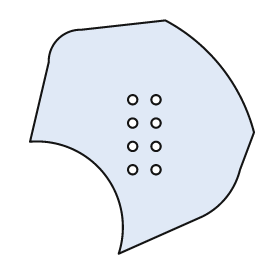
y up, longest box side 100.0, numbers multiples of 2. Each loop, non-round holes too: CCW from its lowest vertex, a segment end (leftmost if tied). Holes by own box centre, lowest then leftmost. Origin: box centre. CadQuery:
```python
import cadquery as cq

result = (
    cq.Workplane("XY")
    .moveTo(-10.0, -50.0)
    .lineTo(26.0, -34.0)
    .threePointArc((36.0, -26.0), (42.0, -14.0))
    .lineTo(48.0, 2.0)
    .threePointArc((34.0, 30.0), (10.0, 50.0))
    .lineTo(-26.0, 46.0)
    .threePointArc((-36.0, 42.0), (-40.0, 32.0))
    .lineTo(-48.0, -2.0)
    .threePointArc((-16.0, -16.0), (-10.0, -50.0))
    .close()
    .moveTo(-4.0, -14.0)
    .circle(2.0)
    .moveTo(6.0, -14.0)
    .circle(2.0)
    .moveTo(-4.0, -4.0)
    .circle(2.0)
    .moveTo(6.0, -4.0)
    .circle(2.0)
    .moveTo(-4.0, 6.0)
    .circle(2.0)
    .moveTo(6.0, 6.0)
    .circle(2.0)
    .moveTo(-4.0, 16.0)
    .circle(2.0)
    .moveTo(6.0, 16.0)
    .circle(2.0)
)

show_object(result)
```